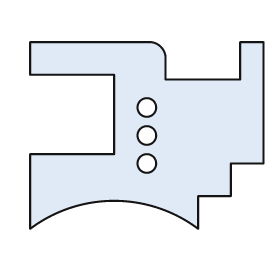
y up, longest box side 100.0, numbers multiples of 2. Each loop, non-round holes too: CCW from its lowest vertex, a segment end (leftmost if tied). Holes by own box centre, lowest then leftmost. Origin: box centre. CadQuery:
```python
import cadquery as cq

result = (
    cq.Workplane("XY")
    .moveTo(-50.0, -40.0)
    .threePointArc((-14.0, -28.0), (22.0, -40.0))
    .lineTo(22.0, -26.0)
    .lineTo(36.0, -26.0)
    .lineTo(36.0, -12.0)
    .lineTo(50.0, -12.0)
    .lineTo(50.0, 40.0)
    .lineTo(40.0, 40.0)
    .lineTo(40.0, 24.0)
    .lineTo(8.0, 24.0)
    .lineTo(8.0, 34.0)
    .threePointArc((6.0, 38.0), (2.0, 40.0))
    .lineTo(-50.0, 40.0)
    .lineTo(-50.0, 26.0)
    .lineTo(-14.0, 26.0)
    .lineTo(-14.0, -8.0)
    .lineTo(-50.0, -8.0)
    .close()
    .moveTo(0.0, -12.0)
    .circle(4.0)
    .moveTo(0.0, 0.0)
    .circle(4.0)
    .moveTo(0.0, 12.0)
    .circle(4.0)
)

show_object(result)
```